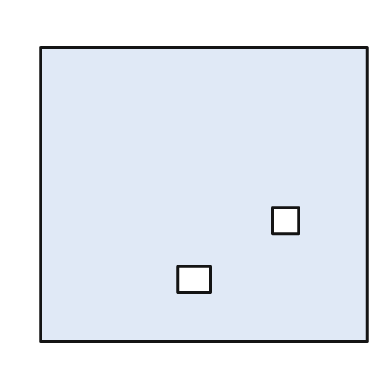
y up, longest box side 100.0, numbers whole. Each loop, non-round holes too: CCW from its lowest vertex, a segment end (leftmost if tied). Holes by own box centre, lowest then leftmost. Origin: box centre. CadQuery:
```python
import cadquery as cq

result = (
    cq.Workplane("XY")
    .moveTo(-50.0, -45.0)
    .lineTo(50.0, -45.0)
    .lineTo(50.0, 45.0)
    .lineTo(-50.0, 45.0)
    .close()
    .moveTo(-8.0, -30.0)
    .lineTo(2.0, -30.0)
    .lineTo(2.0, -22.0)
    .lineTo(-8.0, -22.0)
    .close()
    .moveTo(21.0, -12.0)
    .lineTo(29.0, -12.0)
    .lineTo(29.0, -4.0)
    .lineTo(21.0, -4.0)
    .close()
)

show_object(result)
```